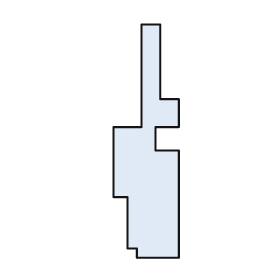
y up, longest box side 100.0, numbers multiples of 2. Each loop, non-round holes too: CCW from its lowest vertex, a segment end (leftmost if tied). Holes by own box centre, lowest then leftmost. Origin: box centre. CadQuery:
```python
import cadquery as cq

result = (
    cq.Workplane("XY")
    .moveTo(-4.0, -50.0)
    .lineTo(14.0, -50.0)
    .lineTo(14.0, -4.0)
    .lineTo(4.0, -4.0)
    .lineTo(4.0, 6.0)
    .lineTo(14.0, 6.0)
    .lineTo(14.0, 18.0)
    .lineTo(6.0, 18.0)
    .lineTo(6.0, 50.0)
    .lineTo(-2.0, 50.0)
    .lineTo(-2.0, 6.0)
    .lineTo(-14.0, 6.0)
    .lineTo(-14.0, -24.0)
    .lineTo(-8.0, -24.0)
    .lineTo(-8.0, -46.0)
    .lineTo(-4.0, -46.0)
    .close()
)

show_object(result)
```